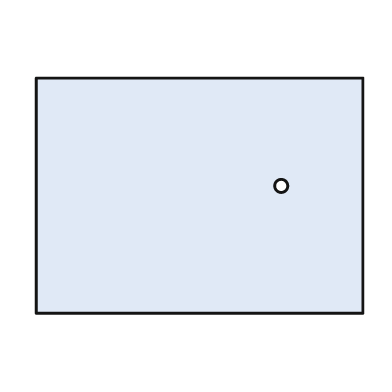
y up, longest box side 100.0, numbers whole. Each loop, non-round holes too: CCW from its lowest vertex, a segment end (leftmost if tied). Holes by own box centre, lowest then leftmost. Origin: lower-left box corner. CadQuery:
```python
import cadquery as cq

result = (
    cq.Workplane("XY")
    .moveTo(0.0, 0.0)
    .lineTo(100.0, 0.0)
    .lineTo(100.0, 72.0)
    .lineTo(0.0, 72.0)
    .close()
    .moveTo(75.0, 39.0)
    .circle(2.0)
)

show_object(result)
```